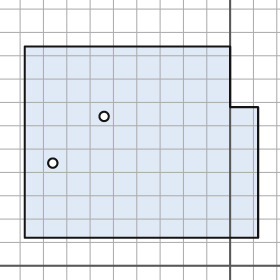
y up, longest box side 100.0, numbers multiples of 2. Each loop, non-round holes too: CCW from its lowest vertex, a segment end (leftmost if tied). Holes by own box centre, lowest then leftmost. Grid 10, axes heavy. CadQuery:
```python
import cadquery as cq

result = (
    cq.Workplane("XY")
    .moveTo(-88.0, 12.0)
    .lineTo(12.0, 12.0)
    .lineTo(12.0, 68.0)
    .lineTo(0.0, 68.0)
    .lineTo(0.0, 94.0)
    .lineTo(-88.0, 94.0)
    .close()
    .moveTo(-76.0, 44.0)
    .circle(2.0)
    .moveTo(-54.0, 64.0)
    .circle(2.0)
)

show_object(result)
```